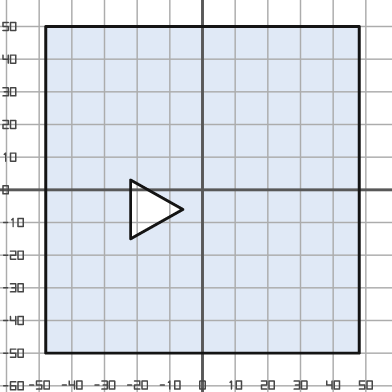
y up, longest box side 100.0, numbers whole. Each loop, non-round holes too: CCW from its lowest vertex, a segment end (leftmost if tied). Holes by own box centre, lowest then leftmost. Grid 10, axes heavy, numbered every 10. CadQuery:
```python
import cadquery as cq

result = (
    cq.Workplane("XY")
    .moveTo(-48.0, -50.0)
    .lineTo(48.0, -50.0)
    .lineTo(48.0, 50.0)
    .lineTo(-48.0, 50.0)
    .close()
    .moveTo(-22.0, -15.0)
    .lineTo(-6.0, -6.0)
    .lineTo(-22.0, 3.0)
    .close()
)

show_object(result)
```